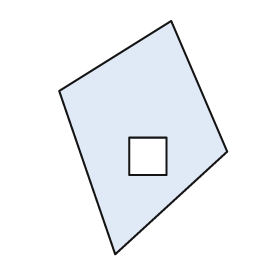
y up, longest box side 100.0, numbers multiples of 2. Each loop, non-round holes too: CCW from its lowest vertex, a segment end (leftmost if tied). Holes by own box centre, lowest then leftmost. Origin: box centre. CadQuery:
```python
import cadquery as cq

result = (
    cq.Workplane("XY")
    .moveTo(-12.0, -50.0)
    .lineTo(36.0, -6.0)
    .lineTo(12.0, 50.0)
    .lineTo(-36.0, 20.0)
    .close()
    .moveTo(-6.0, -16.0)
    .lineTo(10.0, -16.0)
    .lineTo(10.0, 0.0)
    .lineTo(-6.0, 0.0)
    .close()
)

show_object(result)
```